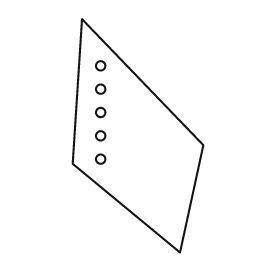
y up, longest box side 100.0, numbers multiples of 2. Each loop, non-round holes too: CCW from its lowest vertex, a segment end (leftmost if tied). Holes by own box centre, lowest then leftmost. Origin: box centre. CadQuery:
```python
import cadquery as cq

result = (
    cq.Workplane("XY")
    .moveTo(18.0, -50.0)
    .lineTo(28.0, -4.0)
    .lineTo(-24.0, 50.0)
    .lineTo(-28.0, -12.0)
    .close()
    .moveTo(-16.0, -10.0)
    .circle(2.0)
    .moveTo(-16.0, 0.0)
    .circle(2.0)
    .moveTo(-16.0, 10.0)
    .circle(2.0)
    .moveTo(-16.0, 20.0)
    .circle(2.0)
    .moveTo(-16.0, 30.0)
    .circle(2.0)
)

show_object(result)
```